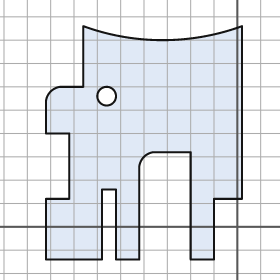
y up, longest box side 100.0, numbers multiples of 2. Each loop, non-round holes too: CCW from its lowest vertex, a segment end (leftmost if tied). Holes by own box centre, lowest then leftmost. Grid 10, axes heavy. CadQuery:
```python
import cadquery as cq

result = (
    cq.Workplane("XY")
    .moveTo(-82.0, -14.0)
    .lineTo(-58.0, -14.0)
    .lineTo(-58.0, 16.0)
    .lineTo(-52.0, 16.0)
    .lineTo(-52.0, -14.0)
    .lineTo(-42.0, -14.0)
    .lineTo(-42.0, 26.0)
    .threePointArc((-40.0, 30.0), (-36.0, 32.0))
    .lineTo(-20.0, 32.0)
    .lineTo(-20.0, -14.0)
    .lineTo(-10.0, -14.0)
    .lineTo(-10.0, 12.0)
    .lineTo(2.0, 12.0)
    .lineTo(2.0, 86.0)
    .threePointArc((-32.0, 80.0), (-66.0, 86.0))
    .lineTo(-66.0, 60.0)
    .lineTo(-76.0, 60.0)
    .threePointArc((-80.0, 58.0), (-82.0, 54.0))
    .lineTo(-82.0, 40.0)
    .lineTo(-72.0, 40.0)
    .lineTo(-72.0, 12.0)
    .lineTo(-82.0, 12.0)
    .close()
    .moveTo(-56.0, 56.0)
    .circle(4.0)
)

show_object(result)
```